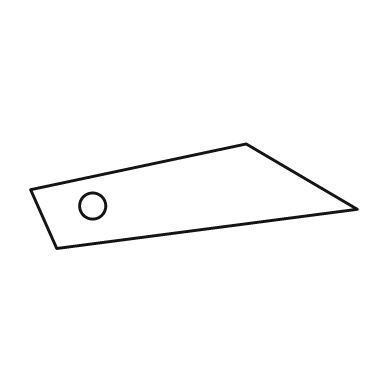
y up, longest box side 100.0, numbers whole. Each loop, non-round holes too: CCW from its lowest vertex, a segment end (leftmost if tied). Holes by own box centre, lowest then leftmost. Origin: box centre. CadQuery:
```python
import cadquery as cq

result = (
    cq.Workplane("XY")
    .moveTo(-42.0, -16.0)
    .lineTo(50.0, -4.0)
    .lineTo(16.0, 16.0)
    .lineTo(-50.0, 2.0)
    .close()
    .moveTo(-31.0, -3.0)
    .circle(4.0)
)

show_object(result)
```